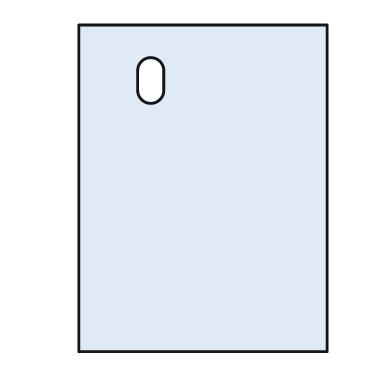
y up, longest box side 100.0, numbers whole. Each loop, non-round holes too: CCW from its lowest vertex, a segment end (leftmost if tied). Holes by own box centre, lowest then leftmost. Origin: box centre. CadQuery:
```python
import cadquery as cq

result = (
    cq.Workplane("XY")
    .moveTo(-38.0, -50.0)
    .lineTo(38.0, -50.0)
    .lineTo(38.0, 50.0)
    .lineTo(-38.0, 50.0)
    .close()
    .moveTo(-20.0, 30.0)
    .threePointArc((-16.0, 26.0), (-12.0, 30.0))
    .lineTo(-12.0, 36.0)
    .threePointArc((-16.0, 40.0), (-20.0, 36.0))
    .close()
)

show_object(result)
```